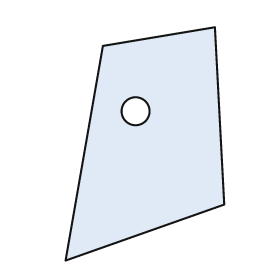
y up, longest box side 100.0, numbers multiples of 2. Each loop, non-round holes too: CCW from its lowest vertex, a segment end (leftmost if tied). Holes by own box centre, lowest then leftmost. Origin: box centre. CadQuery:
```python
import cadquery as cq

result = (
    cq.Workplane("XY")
    .moveTo(-34.0, -50.0)
    .lineTo(34.0, -26.0)
    .lineTo(30.0, 50.0)
    .lineTo(-18.0, 42.0)
    .close()
    .moveTo(-4.0, 14.0)
    .circle(6.0)
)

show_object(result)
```